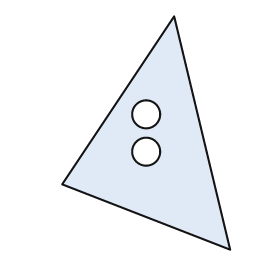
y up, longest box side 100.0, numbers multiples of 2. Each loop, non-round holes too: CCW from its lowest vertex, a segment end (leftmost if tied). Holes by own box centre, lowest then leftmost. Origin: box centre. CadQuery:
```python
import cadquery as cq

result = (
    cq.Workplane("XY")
    .moveTo(36.0, -50.0)
    .lineTo(12.0, 50.0)
    .lineTo(-36.0, -22.0)
    .close()
    .moveTo(0.0, -8.0)
    .circle(6.0)
    .moveTo(0.0, 8.0)
    .circle(6.0)
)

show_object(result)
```